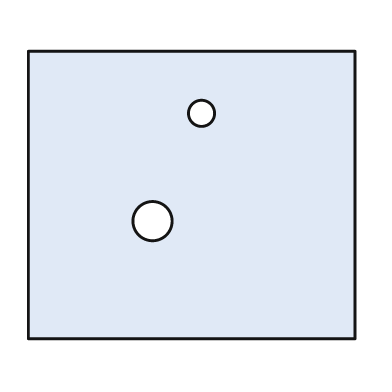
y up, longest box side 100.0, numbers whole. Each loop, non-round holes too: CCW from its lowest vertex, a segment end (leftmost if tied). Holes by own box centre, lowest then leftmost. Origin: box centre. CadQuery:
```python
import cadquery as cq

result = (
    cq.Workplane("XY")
    .moveTo(-50.0, -44.0)
    .lineTo(50.0, -44.0)
    .lineTo(50.0, 44.0)
    .lineTo(-50.0, 44.0)
    .close()
    .moveTo(-12.0, -8.0)
    .circle(6.0)
    .moveTo(3.0, 25.0)
    .circle(4.0)
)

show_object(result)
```